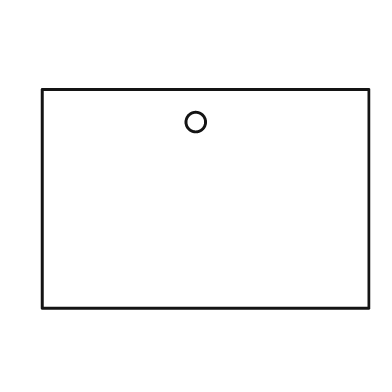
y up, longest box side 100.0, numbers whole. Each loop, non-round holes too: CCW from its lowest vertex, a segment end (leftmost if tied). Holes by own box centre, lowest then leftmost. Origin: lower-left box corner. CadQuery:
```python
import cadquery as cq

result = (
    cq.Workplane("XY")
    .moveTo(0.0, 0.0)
    .lineTo(100.0, 0.0)
    .lineTo(100.0, 67.0)
    .lineTo(0.0, 67.0)
    .close()
    .moveTo(47.0, 57.0)
    .circle(3.0)
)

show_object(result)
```